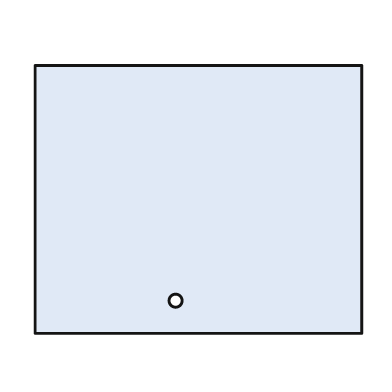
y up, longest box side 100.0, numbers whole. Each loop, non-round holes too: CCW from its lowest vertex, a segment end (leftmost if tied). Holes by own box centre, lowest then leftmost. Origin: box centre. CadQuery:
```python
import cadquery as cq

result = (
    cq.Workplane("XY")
    .moveTo(-50.0, -41.0)
    .lineTo(50.0, -41.0)
    .lineTo(50.0, 41.0)
    .lineTo(-50.0, 41.0)
    .close()
    .moveTo(-7.0, -31.0)
    .circle(2.0)
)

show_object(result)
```